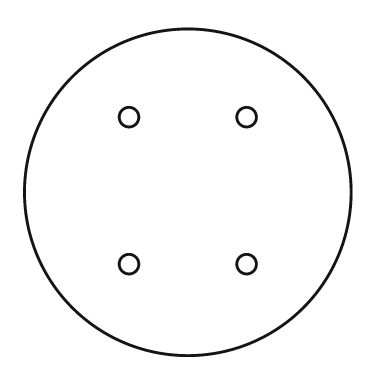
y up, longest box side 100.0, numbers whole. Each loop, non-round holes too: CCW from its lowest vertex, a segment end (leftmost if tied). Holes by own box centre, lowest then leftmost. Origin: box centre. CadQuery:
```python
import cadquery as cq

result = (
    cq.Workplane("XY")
    .moveTo(0.0, 0.0)
    .circle(50.0)
    .moveTo(-18.0, -22.0)
    .circle(3.0)
    .moveTo(18.0, -22.0)
    .circle(3.0)
    .moveTo(-18.0, 23.0)
    .circle(3.0)
    .moveTo(18.0, 23.0)
    .circle(3.0)
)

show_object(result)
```